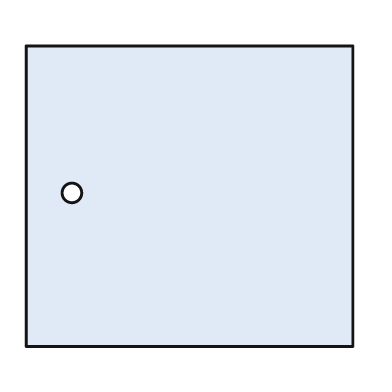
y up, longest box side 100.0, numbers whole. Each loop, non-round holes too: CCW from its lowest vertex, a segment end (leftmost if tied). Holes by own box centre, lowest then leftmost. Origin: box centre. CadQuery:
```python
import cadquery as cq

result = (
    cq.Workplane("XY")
    .moveTo(-50.0, -46.0)
    .lineTo(50.0, -46.0)
    .lineTo(50.0, 46.0)
    .lineTo(-50.0, 46.0)
    .close()
    .moveTo(-36.0, 1.0)
    .circle(3.0)
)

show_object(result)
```